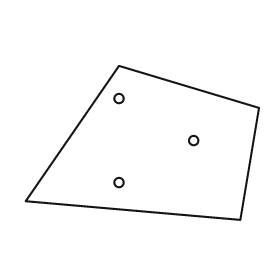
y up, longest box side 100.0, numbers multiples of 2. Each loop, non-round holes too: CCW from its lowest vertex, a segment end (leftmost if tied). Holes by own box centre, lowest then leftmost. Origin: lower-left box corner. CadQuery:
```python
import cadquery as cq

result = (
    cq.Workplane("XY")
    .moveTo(92.0, 0.0)
    .lineTo(100.0, 48.0)
    .lineTo(40.0, 66.0)
    .lineTo(0.0, 8.0)
    .close()
    .moveTo(40.0, 16.0)
    .circle(2.0)
    .moveTo(72.0, 34.0)
    .circle(2.0)
    .moveTo(40.0, 52.0)
    .circle(2.0)
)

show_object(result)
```